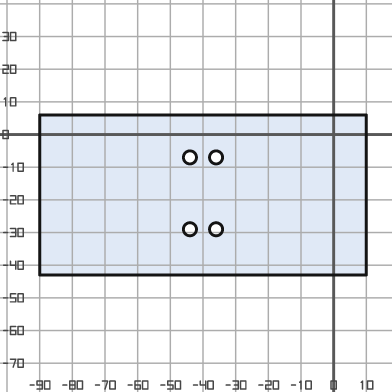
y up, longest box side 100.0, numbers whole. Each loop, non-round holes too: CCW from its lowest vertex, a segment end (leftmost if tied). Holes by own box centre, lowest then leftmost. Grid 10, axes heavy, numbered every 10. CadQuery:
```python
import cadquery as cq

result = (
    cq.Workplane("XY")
    .moveTo(-90.0, -43.0)
    .lineTo(10.0, -43.0)
    .lineTo(10.0, 6.0)
    .lineTo(-90.0, 6.0)
    .close()
    .moveTo(-44.0, -29.0)
    .circle(2.0)
    .moveTo(-36.0, -29.0)
    .circle(2.0)
    .moveTo(-44.0, -7.0)
    .circle(2.0)
    .moveTo(-36.0, -7.0)
    .circle(2.0)
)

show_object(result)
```